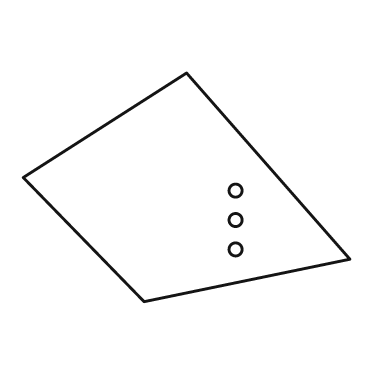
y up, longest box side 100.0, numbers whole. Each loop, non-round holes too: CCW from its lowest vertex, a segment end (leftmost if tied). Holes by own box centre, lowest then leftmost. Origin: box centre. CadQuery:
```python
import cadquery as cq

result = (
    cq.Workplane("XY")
    .moveTo(-13.0, -35.0)
    .lineTo(50.0, -22.0)
    .lineTo(0.0, 35.0)
    .lineTo(-50.0, 3.0)
    .close()
    .moveTo(15.0, -19.0)
    .circle(2.0)
    .moveTo(15.0, -10.0)
    .circle(2.0)
    .moveTo(15.0, -1.0)
    .circle(2.0)
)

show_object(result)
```